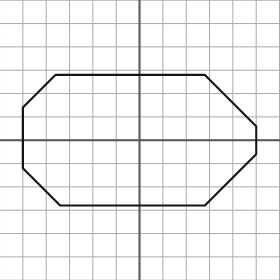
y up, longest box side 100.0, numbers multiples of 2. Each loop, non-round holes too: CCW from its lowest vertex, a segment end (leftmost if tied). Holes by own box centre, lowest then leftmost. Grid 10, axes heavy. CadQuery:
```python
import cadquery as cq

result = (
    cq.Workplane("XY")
    .moveTo(-34.0, -28.0)
    .lineTo(28.0, -28.0)
    .lineTo(50.0, -6.0)
    .lineTo(50.0, 6.0)
    .lineTo(28.0, 28.0)
    .lineTo(-36.0, 28.0)
    .lineTo(-50.0, 14.0)
    .lineTo(-50.0, -12.0)
    .close()
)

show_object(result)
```